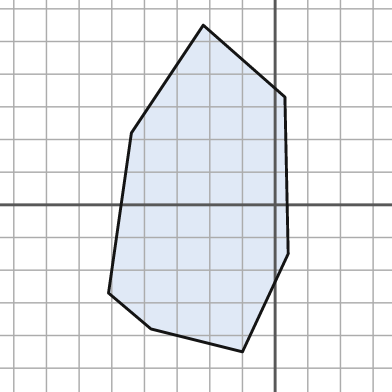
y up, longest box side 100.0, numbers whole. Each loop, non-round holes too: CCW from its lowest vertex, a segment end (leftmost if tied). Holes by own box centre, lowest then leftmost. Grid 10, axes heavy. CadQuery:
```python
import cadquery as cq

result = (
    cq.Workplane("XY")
    .moveTo(-10.0, -45.0)
    .lineTo(4.0, -15.0)
    .lineTo(3.0, 33.0)
    .lineTo(-22.0, 55.0)
    .lineTo(-44.0, 22.0)
    .lineTo(-51.0, -27.0)
    .lineTo(-38.0, -38.0)
    .close()
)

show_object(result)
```